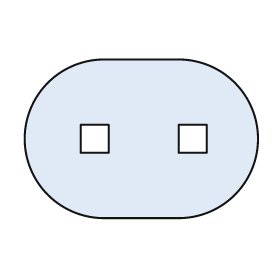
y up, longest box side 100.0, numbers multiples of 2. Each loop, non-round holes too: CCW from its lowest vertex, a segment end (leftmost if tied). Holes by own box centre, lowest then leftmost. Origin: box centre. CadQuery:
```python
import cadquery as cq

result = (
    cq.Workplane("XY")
    .moveTo(-16.0, -34.0)
    .lineTo(16.0, -34.0)
    .threePointArc((50.0, 0.0), (16.0, 34.0))
    .lineTo(-16.0, 34.0)
    .threePointArc((-50.0, 0.0), (-16.0, -34.0))
    .close()
    .moveTo(-26.0, -6.0)
    .lineTo(-14.0, -6.0)
    .lineTo(-14.0, 6.0)
    .lineTo(-26.0, 6.0)
    .close()
    .moveTo(16.0, -6.0)
    .lineTo(28.0, -6.0)
    .lineTo(28.0, 6.0)
    .lineTo(16.0, 6.0)
    .close()
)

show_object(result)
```